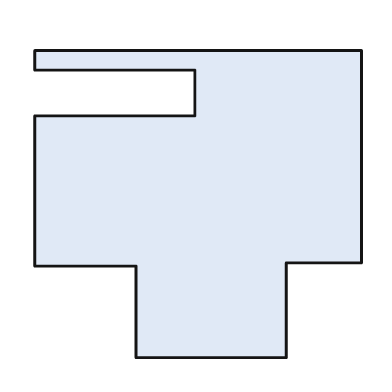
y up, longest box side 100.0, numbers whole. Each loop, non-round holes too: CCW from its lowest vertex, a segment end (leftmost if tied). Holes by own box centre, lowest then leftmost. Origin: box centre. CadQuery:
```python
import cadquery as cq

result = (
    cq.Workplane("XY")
    .moveTo(-19.0, -47.0)
    .lineTo(27.0, -47.0)
    .lineTo(27.0, -18.0)
    .lineTo(50.0, -18.0)
    .lineTo(50.0, 47.0)
    .lineTo(-50.0, 47.0)
    .lineTo(-50.0, 41.0)
    .lineTo(-1.0, 41.0)
    .lineTo(-1.0, 27.0)
    .lineTo(-50.0, 27.0)
    .lineTo(-50.0, -19.0)
    .lineTo(-19.0, -19.0)
    .close()
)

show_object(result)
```